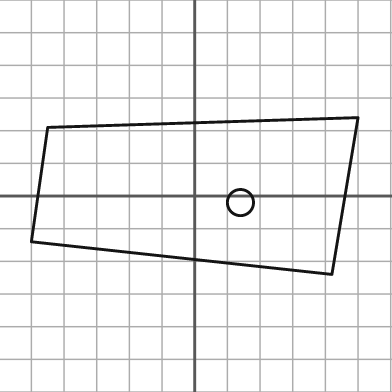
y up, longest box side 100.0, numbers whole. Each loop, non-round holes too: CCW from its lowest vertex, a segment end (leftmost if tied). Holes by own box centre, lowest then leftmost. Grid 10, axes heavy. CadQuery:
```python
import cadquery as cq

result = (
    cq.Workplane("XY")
    .moveTo(42.0, -24.0)
    .lineTo(50.0, 24.0)
    .lineTo(-45.0, 21.0)
    .lineTo(-50.0, -14.0)
    .close()
    .moveTo(14.0, -2.0)
    .circle(4.0)
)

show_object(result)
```